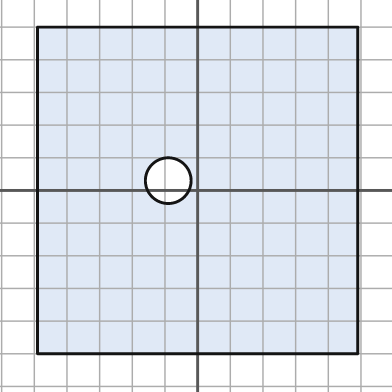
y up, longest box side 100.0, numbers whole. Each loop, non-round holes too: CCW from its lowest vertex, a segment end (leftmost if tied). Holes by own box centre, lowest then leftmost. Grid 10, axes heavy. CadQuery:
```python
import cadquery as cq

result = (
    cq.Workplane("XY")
    .moveTo(-49.0, -50.0)
    .lineTo(49.0, -50.0)
    .lineTo(49.0, 50.0)
    .lineTo(-49.0, 50.0)
    .close()
    .moveTo(-9.0, 3.0)
    .circle(7.0)
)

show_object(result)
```